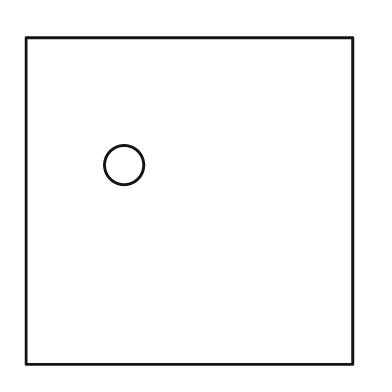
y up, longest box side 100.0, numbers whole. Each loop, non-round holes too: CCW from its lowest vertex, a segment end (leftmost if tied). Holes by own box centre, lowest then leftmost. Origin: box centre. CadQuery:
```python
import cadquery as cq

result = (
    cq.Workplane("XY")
    .moveTo(-50.0, -50.0)
    .lineTo(50.0, -50.0)
    .lineTo(50.0, 50.0)
    .lineTo(-50.0, 50.0)
    .close()
    .moveTo(-20.0, 11.0)
    .circle(6.0)
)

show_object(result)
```